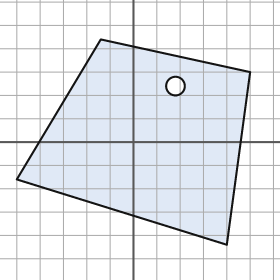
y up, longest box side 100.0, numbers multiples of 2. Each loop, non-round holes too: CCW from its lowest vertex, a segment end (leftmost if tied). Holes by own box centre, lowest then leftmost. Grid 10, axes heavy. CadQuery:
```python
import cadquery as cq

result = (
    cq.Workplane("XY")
    .moveTo(40.0, -44.0)
    .lineTo(50.0, 30.0)
    .lineTo(-14.0, 44.0)
    .lineTo(-50.0, -16.0)
    .close()
    .moveTo(18.0, 24.0)
    .circle(4.0)
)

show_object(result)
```